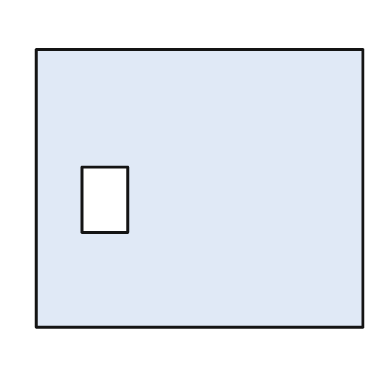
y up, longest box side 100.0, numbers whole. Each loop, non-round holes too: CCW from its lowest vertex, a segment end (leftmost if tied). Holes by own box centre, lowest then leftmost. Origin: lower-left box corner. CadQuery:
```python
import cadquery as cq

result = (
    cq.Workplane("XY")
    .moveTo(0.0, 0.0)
    .lineTo(100.0, 0.0)
    .lineTo(100.0, 85.0)
    .lineTo(0.0, 85.0)
    .close()
    .moveTo(14.0, 29.0)
    .lineTo(28.0, 29.0)
    .lineTo(28.0, 49.0)
    .lineTo(14.0, 49.0)
    .close()
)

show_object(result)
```